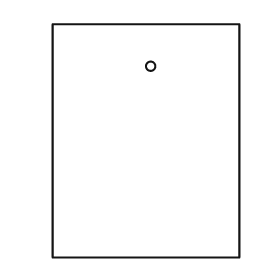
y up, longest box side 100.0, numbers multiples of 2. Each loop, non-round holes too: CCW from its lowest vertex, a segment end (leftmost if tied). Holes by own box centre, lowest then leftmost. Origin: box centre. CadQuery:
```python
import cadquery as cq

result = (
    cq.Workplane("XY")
    .moveTo(-40.0, -50.0)
    .lineTo(40.0, -50.0)
    .lineTo(40.0, 50.0)
    .lineTo(-40.0, 50.0)
    .close()
    .moveTo(2.0, 32.0)
    .circle(2.0)
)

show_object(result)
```